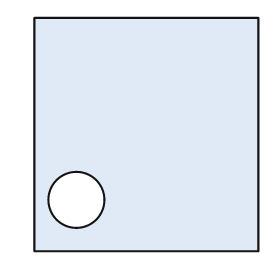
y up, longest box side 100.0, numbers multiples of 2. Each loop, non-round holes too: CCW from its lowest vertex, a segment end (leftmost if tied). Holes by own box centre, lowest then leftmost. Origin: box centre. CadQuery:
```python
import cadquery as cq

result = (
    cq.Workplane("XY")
    .moveTo(-48.0, -50.0)
    .lineTo(48.0, -50.0)
    .lineTo(48.0, 50.0)
    .lineTo(-48.0, 50.0)
    .close()
    .moveTo(-30.0, -28.0)
    .circle(12.0)
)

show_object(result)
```